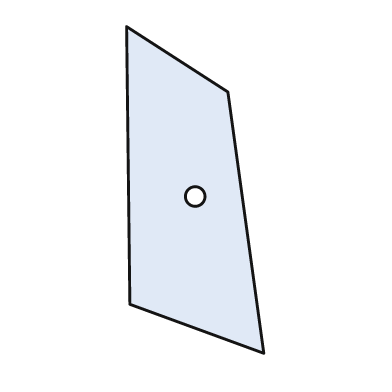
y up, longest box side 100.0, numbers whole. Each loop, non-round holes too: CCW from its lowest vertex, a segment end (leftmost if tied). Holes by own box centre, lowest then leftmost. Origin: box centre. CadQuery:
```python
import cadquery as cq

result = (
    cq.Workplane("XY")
    .moveTo(21.0, -50.0)
    .lineTo(10.0, 30.0)
    .lineTo(-21.0, 50.0)
    .lineTo(-20.0, -35.0)
    .close()
    .moveTo(0.0, -2.0)
    .circle(3.0)
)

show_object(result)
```